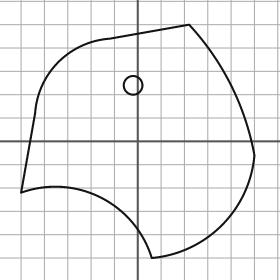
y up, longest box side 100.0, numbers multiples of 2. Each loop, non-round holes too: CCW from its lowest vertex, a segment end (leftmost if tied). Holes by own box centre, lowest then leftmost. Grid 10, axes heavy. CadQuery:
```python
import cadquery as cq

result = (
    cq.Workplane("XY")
    .moveTo(6.0, -50.0)
    .threePointArc((36.0, -36.0), (50.0, -6.0))
    .threePointArc((40.0, 24.0), (22.0, 50.0))
    .lineTo(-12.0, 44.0)
    .threePointArc((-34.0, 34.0), (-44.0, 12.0))
    .lineTo(-50.0, -22.0)
    .threePointArc((-16.0, -24.0), (6.0, -50.0))
    .close()
    .moveTo(-2.0, 24.0)
    .circle(4.0)
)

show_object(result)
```